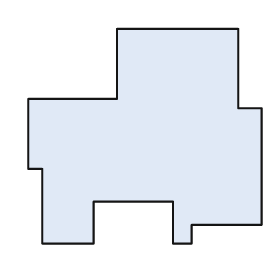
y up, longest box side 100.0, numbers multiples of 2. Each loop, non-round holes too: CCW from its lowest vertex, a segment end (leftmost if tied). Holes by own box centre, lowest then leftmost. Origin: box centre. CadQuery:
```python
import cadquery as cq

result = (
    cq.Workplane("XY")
    .moveTo(-44.0, -46.0)
    .lineTo(-22.0, -46.0)
    .lineTo(-22.0, -28.0)
    .lineTo(12.0, -28.0)
    .lineTo(12.0, -46.0)
    .lineTo(20.0, -46.0)
    .lineTo(20.0, -38.0)
    .lineTo(50.0, -38.0)
    .lineTo(50.0, 12.0)
    .lineTo(40.0, 12.0)
    .lineTo(40.0, 46.0)
    .lineTo(-12.0, 46.0)
    .lineTo(-12.0, 16.0)
    .lineTo(-50.0, 16.0)
    .lineTo(-50.0, -14.0)
    .lineTo(-44.0, -14.0)
    .close()
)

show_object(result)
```